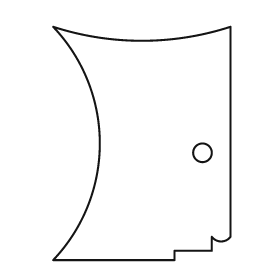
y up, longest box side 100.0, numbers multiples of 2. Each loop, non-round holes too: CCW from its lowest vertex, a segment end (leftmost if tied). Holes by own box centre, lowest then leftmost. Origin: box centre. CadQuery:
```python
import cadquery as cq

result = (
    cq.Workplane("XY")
    .moveTo(-38.0, -50.0)
    .lineTo(14.0, -50.0)
    .lineTo(14.0, -46.0)
    .lineTo(30.0, -46.0)
    .lineTo(30.0, -40.0)
    .threePointArc((34.0, -42.0), (38.0, -40.0))
    .lineTo(38.0, 50.0)
    .threePointArc((0.0, 44.0), (-38.0, 50.0))
    .threePointArc((-18.0, 0.0), (-38.0, -50.0))
    .close()
    .moveTo(26.0, -4.0)
    .circle(4.0)
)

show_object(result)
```